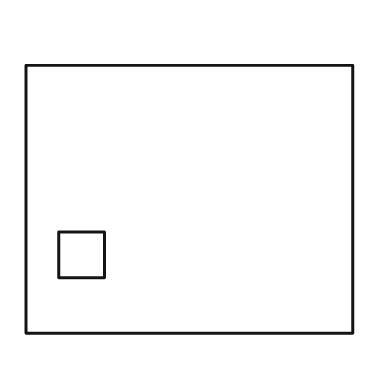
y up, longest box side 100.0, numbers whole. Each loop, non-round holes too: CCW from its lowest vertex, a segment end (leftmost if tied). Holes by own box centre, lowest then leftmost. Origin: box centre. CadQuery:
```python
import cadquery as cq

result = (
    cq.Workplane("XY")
    .moveTo(-50.0, -41.0)
    .lineTo(50.0, -41.0)
    .lineTo(50.0, 41.0)
    .lineTo(-50.0, 41.0)
    .close()
    .moveTo(-40.0, -24.0)
    .lineTo(-26.0, -24.0)
    .lineTo(-26.0, -10.0)
    .lineTo(-40.0, -10.0)
    .close()
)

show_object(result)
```